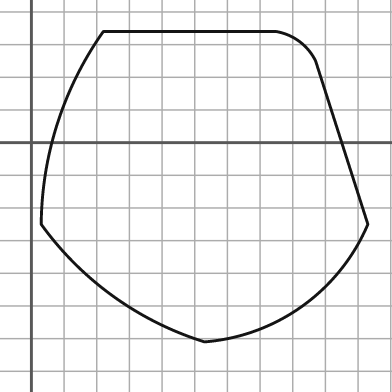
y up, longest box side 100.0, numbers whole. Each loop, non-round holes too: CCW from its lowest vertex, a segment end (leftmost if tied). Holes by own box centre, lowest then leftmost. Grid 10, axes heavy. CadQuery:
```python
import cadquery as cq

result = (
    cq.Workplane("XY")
    .moveTo(53.0, -61.0)
    .threePointArc((83.0, -50.0), (103.0, -25.0))
    .lineTo(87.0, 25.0)
    .threePointArc((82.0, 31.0), (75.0, 34.0))
    .lineTo(22.0, 34.0)
    .threePointArc((8.0, 6.0), (3.0, -25.0))
    .threePointArc((25.0, -47.0), (53.0, -61.0))
    .close()
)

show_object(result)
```